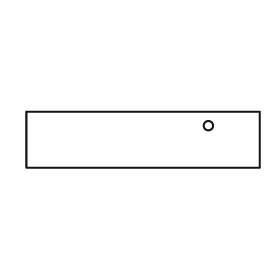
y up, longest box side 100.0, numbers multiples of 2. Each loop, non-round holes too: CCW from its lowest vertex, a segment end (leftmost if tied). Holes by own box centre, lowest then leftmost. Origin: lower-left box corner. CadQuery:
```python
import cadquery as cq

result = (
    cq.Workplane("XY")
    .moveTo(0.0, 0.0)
    .lineTo(100.0, 0.0)
    .lineTo(100.0, 24.0)
    .lineTo(0.0, 24.0)
    .close()
    .moveTo(78.0, 18.0)
    .circle(2.0)
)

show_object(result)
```